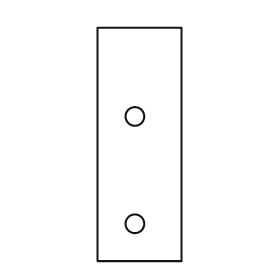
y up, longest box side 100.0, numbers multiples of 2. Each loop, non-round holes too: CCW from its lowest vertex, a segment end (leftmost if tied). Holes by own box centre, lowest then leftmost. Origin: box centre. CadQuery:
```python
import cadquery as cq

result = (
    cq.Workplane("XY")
    .moveTo(-18.0, -50.0)
    .lineTo(18.0, -50.0)
    .lineTo(18.0, 50.0)
    .lineTo(-18.0, 50.0)
    .close()
    .moveTo(-2.0, -34.0)
    .circle(4.0)
    .moveTo(-2.0, 12.0)
    .circle(4.0)
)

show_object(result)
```